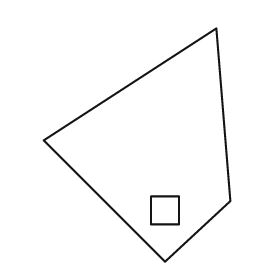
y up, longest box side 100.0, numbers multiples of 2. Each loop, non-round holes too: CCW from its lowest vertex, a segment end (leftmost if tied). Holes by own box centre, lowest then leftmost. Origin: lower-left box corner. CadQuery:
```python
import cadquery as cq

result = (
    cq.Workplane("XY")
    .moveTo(52.0, 0.0)
    .lineTo(80.0, 26.0)
    .lineTo(74.0, 100.0)
    .lineTo(0.0, 52.0)
    .close()
    .moveTo(46.0, 16.0)
    .lineTo(58.0, 16.0)
    .lineTo(58.0, 28.0)
    .lineTo(46.0, 28.0)
    .close()
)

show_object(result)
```